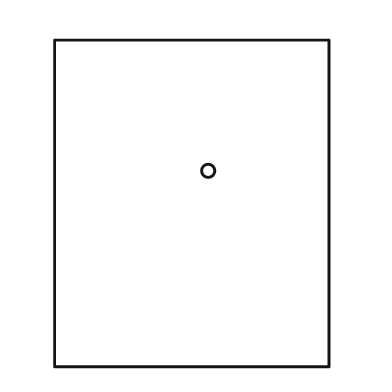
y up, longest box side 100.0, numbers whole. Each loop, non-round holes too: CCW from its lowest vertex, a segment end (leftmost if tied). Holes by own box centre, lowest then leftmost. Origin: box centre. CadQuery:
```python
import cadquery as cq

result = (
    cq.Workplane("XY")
    .moveTo(-42.0, -50.0)
    .lineTo(42.0, -50.0)
    .lineTo(42.0, 50.0)
    .lineTo(-42.0, 50.0)
    .close()
    .moveTo(5.0, 10.0)
    .circle(2.0)
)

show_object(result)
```